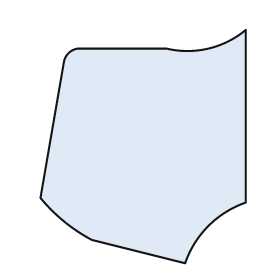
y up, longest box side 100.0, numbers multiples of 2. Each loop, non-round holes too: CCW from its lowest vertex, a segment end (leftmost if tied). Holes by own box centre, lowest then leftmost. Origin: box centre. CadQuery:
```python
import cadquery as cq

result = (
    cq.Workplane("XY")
    .moveTo(18.0, -50.0)
    .threePointArc((28.0, -34.0), (44.0, -24.0))
    .lineTo(44.0, 50.0)
    .threePointArc((28.0, 42.0), (10.0, 42.0))
    .lineTo(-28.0, 42.0)
    .threePointArc((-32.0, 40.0), (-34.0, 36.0))
    .lineTo(-44.0, -22.0)
    .threePointArc((-34.0, -32.0), (-22.0, -40.0))
    .close()
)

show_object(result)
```